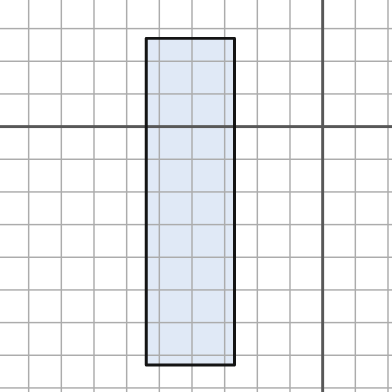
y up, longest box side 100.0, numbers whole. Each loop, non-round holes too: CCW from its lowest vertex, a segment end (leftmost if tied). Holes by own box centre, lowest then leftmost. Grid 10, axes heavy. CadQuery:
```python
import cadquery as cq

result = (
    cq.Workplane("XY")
    .moveTo(-54.0, -73.0)
    .lineTo(-27.0, -73.0)
    .lineTo(-27.0, 27.0)
    .lineTo(-54.0, 27.0)
    .close()
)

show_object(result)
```